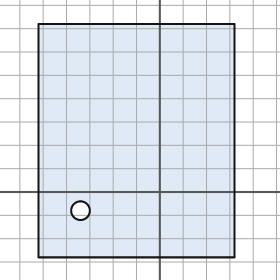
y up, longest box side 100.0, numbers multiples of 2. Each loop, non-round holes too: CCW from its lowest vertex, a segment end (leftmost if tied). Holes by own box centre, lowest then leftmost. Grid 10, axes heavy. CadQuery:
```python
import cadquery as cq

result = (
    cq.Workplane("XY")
    .moveTo(-52.0, -28.0)
    .lineTo(32.0, -28.0)
    .lineTo(32.0, 72.0)
    .lineTo(-52.0, 72.0)
    .close()
    .moveTo(-34.0, -8.0)
    .circle(4.0)
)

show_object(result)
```